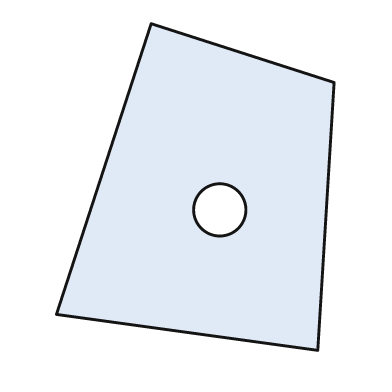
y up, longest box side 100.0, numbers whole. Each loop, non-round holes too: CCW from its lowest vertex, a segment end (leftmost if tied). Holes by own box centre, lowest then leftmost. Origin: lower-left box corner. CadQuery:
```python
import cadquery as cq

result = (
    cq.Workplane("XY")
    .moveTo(80.0, 0.0)
    .lineTo(85.0, 82.0)
    .lineTo(29.0, 100.0)
    .lineTo(0.0, 11.0)
    .close()
    .moveTo(50.0, 43.0)
    .circle(8.0)
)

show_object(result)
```